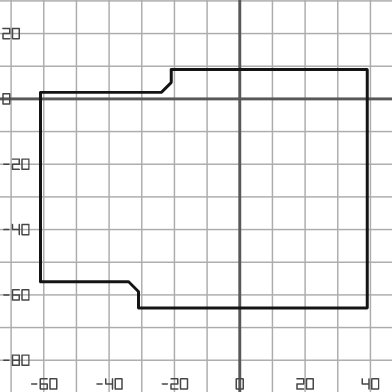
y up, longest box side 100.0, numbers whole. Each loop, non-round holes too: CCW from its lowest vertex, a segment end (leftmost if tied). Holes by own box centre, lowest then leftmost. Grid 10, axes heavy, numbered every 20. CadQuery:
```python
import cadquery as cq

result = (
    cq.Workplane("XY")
    .moveTo(-31.0, -64.0)
    .lineTo(39.0, -64.0)
    .lineTo(39.0, 9.0)
    .lineTo(-21.0, 9.0)
    .lineTo(-21.0, 5.0)
    .lineTo(-24.0, 2.0)
    .lineTo(-61.0, 2.0)
    .lineTo(-61.0, -56.0)
    .lineTo(-34.0, -56.0)
    .lineTo(-31.0, -59.0)
    .close()
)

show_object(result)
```